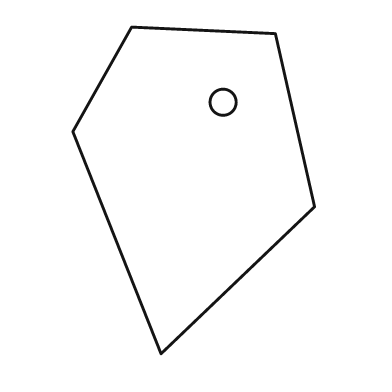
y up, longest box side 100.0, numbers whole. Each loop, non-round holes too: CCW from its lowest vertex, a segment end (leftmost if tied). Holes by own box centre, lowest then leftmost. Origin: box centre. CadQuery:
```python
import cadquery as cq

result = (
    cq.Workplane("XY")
    .moveTo(-10.0, -50.0)
    .lineTo(37.0, -5.0)
    .lineTo(25.0, 48.0)
    .lineTo(-19.0, 50.0)
    .lineTo(-37.0, 18.0)
    .close()
    .moveTo(9.0, 27.0)
    .circle(4.0)
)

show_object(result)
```